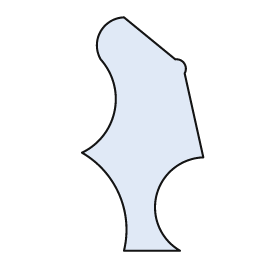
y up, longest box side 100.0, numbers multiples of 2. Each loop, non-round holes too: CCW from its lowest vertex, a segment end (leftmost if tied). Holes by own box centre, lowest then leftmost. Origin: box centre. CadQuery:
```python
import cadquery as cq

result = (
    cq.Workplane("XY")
    .moveTo(-8.0, -50.0)
    .lineTo(16.0, -50.0)
    .threePointArc((6.0, -26.0), (26.0, -10.0))
    .lineTo(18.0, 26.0)
    .threePointArc((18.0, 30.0), (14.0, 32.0))
    .lineTo(-8.0, 50.0)
    .threePointArc((-18.0, 44.0), (-18.0, 32.0))
    .threePointArc((-12.0, 10.0), (-26.0, -8.0))
    .threePointArc((-10.0, -26.0), (-8.0, -50.0))
    .close()
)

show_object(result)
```